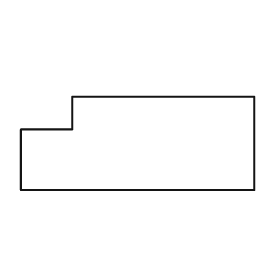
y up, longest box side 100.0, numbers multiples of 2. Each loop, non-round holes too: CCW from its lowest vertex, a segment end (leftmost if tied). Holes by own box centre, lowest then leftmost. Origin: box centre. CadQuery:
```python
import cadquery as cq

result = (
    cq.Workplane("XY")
    .moveTo(-50.0, -20.0)
    .lineTo(50.0, -20.0)
    .lineTo(50.0, 20.0)
    .lineTo(-28.0, 20.0)
    .lineTo(-28.0, 6.0)
    .lineTo(-50.0, 6.0)
    .close()
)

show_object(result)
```